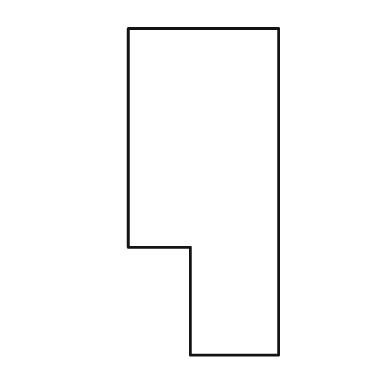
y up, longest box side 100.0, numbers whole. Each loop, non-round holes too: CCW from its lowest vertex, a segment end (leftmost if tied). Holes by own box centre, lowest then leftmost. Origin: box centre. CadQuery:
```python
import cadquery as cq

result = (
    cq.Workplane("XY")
    .moveTo(-4.0, -50.0)
    .lineTo(23.0, -50.0)
    .lineTo(23.0, 50.0)
    .lineTo(-23.0, 50.0)
    .lineTo(-23.0, -17.0)
    .lineTo(-4.0, -17.0)
    .close()
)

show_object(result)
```